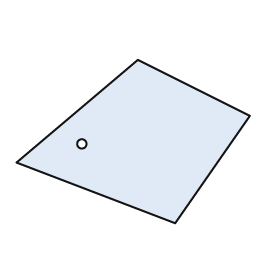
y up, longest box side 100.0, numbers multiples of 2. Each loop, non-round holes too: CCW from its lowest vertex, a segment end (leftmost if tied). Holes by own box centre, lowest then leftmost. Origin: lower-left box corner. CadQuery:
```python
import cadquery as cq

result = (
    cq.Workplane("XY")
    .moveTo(68.0, 0.0)
    .lineTo(100.0, 46.0)
    .lineTo(52.0, 70.0)
    .lineTo(0.0, 26.0)
    .close()
    .moveTo(28.0, 34.0)
    .circle(2.0)
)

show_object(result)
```